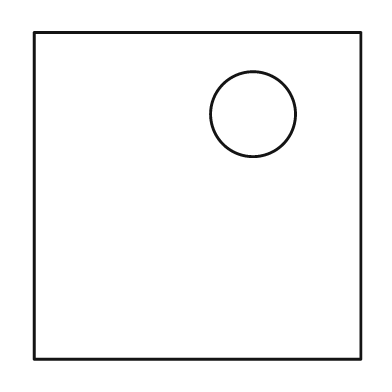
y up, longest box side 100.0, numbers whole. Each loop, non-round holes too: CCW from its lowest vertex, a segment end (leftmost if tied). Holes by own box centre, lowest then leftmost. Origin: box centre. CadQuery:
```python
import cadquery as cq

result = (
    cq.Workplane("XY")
    .moveTo(-50.0, -50.0)
    .lineTo(50.0, -50.0)
    .lineTo(50.0, 50.0)
    .lineTo(-50.0, 50.0)
    .close()
    .moveTo(17.0, 25.0)
    .circle(13.0)
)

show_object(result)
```